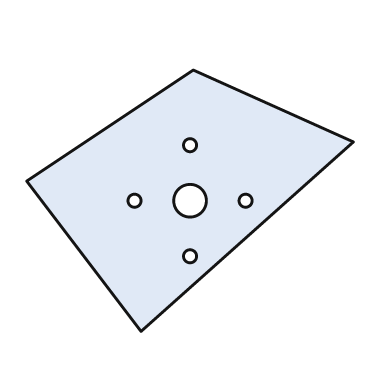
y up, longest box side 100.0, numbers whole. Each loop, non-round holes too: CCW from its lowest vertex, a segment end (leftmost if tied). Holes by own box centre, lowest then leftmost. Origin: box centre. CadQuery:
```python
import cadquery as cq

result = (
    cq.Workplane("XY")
    .moveTo(-15.0, -40.0)
    .lineTo(50.0, 18.0)
    .lineTo(1.0, 40.0)
    .lineTo(-50.0, 6.0)
    .close()
    .moveTo(0.0, -17.0)
    .circle(2.0)
    .moveTo(-17.0, 0.0)
    .circle(2.0)
    .moveTo(0.0, 0.0)
    .circle(5.0)
    .moveTo(17.0, 0.0)
    .circle(2.0)
    .moveTo(0.0, 17.0)
    .circle(2.0)
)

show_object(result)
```